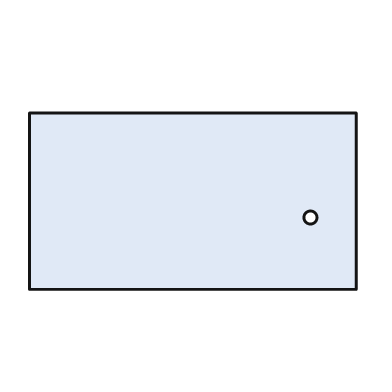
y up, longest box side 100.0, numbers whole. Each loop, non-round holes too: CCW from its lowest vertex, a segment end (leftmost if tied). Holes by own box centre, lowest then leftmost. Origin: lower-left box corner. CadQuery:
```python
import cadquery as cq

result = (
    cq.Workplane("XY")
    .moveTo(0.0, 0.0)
    .lineTo(100.0, 0.0)
    .lineTo(100.0, 54.0)
    .lineTo(0.0, 54.0)
    .close()
    .moveTo(86.0, 22.0)
    .circle(2.0)
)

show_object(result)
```